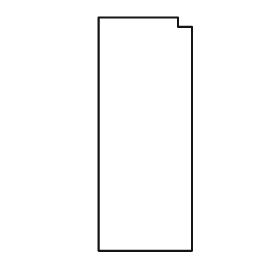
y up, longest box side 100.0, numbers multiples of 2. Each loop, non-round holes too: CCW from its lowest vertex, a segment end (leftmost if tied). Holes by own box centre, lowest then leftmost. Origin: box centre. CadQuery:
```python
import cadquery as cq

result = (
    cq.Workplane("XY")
    .moveTo(-20.0, -50.0)
    .lineTo(20.0, -50.0)
    .lineTo(20.0, 46.0)
    .lineTo(14.0, 46.0)
    .lineTo(14.0, 50.0)
    .lineTo(-20.0, 50.0)
    .close()
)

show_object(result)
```